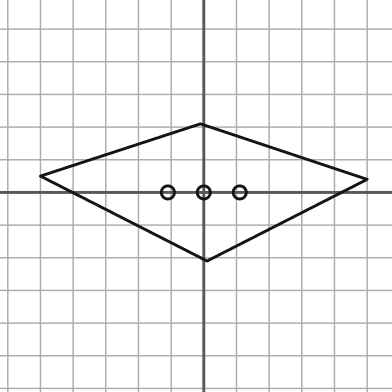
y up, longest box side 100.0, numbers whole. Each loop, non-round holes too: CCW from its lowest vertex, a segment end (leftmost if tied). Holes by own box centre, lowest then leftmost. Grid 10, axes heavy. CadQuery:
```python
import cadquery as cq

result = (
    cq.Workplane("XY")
    .moveTo(1.0, -21.0)
    .lineTo(50.0, 4.0)
    .lineTo(-1.0, 21.0)
    .lineTo(-50.0, 5.0)
    .close()
    .moveTo(-11.0, 0.0)
    .circle(2.0)
    .moveTo(0.0, 0.0)
    .circle(2.0)
    .moveTo(11.0, 0.0)
    .circle(2.0)
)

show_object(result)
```